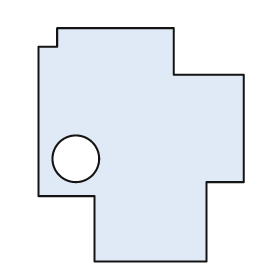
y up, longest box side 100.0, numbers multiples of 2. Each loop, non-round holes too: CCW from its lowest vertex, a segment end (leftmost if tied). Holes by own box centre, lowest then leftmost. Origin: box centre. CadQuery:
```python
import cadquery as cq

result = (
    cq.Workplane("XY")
    .moveTo(-20.0, -50.0)
    .lineTo(28.0, -50.0)
    .lineTo(28.0, -16.0)
    .lineTo(44.0, -16.0)
    .lineTo(44.0, 30.0)
    .lineTo(14.0, 30.0)
    .lineTo(14.0, 50.0)
    .lineTo(-36.0, 50.0)
    .lineTo(-36.0, 42.0)
    .lineTo(-44.0, 42.0)
    .lineTo(-44.0, -22.0)
    .lineTo(-20.0, -22.0)
    .close()
    .moveTo(-28.0, -6.0)
    .circle(10.0)
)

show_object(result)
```